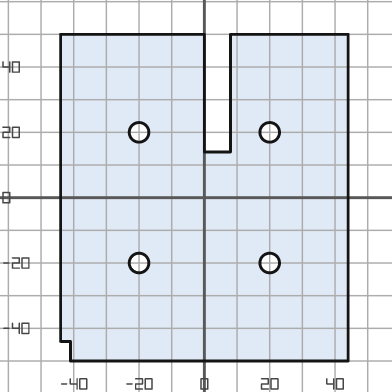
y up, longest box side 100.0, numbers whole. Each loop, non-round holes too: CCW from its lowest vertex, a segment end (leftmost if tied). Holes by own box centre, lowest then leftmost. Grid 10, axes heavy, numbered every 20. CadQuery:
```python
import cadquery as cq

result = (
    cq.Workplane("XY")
    .moveTo(-41.0, -50.0)
    .lineTo(44.0, -50.0)
    .lineTo(44.0, 50.0)
    .lineTo(8.0, 50.0)
    .lineTo(8.0, 14.0)
    .lineTo(0.0, 14.0)
    .lineTo(0.0, 50.0)
    .lineTo(-44.0, 50.0)
    .lineTo(-44.0, -44.0)
    .lineTo(-41.0, -44.0)
    .close()
    .moveTo(-20.0, -20.0)
    .circle(3.0)
    .moveTo(20.0, -20.0)
    .circle(3.0)
    .moveTo(-20.0, 20.0)
    .circle(3.0)
    .moveTo(20.0, 20.0)
    .circle(3.0)
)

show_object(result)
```